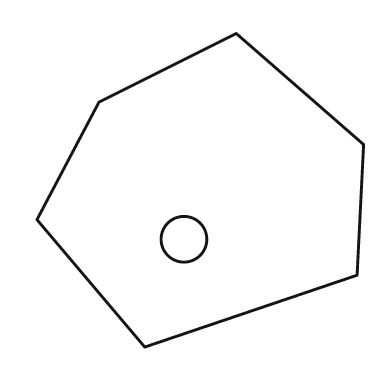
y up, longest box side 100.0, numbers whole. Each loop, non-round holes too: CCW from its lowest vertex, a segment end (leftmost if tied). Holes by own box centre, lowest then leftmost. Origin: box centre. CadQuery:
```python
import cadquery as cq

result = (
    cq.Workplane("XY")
    .moveTo(-17.0, -48.0)
    .lineTo(48.0, -26.0)
    .lineTo(50.0, 14.0)
    .lineTo(11.0, 48.0)
    .lineTo(-31.0, 27.0)
    .lineTo(-50.0, -9.0)
    .close()
    .moveTo(-5.0, -15.0)
    .circle(7.0)
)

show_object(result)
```